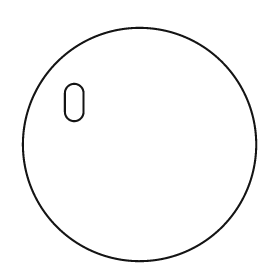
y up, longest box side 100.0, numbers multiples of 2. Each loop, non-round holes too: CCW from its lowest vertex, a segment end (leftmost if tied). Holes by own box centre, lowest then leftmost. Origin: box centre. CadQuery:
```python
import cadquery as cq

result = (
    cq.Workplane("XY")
    .moveTo(0.0, 0.0)
    .circle(50.0)
    .moveTo(-32.0, 14.0)
    .threePointArc((-28.0, 10.0), (-24.0, 14.0))
    .lineTo(-24.0, 22.0)
    .threePointArc((-28.0, 26.0), (-32.0, 22.0))
    .close()
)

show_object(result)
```